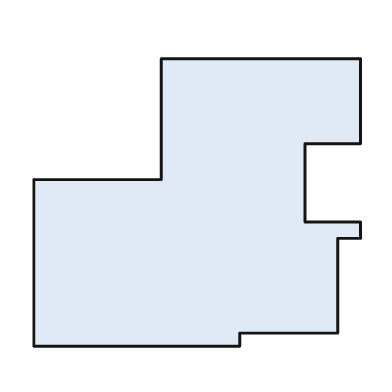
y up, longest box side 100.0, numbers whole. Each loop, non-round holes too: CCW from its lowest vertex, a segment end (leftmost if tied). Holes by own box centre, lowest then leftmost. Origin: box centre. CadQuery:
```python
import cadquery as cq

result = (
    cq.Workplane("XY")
    .moveTo(-50.0, -44.0)
    .lineTo(13.0, -44.0)
    .lineTo(13.0, -40.0)
    .lineTo(43.0, -40.0)
    .lineTo(43.0, -11.0)
    .lineTo(50.0, -11.0)
    .lineTo(50.0, -6.0)
    .lineTo(33.0, -6.0)
    .lineTo(33.0, 18.0)
    .lineTo(50.0, 18.0)
    .lineTo(50.0, 44.0)
    .lineTo(-11.0, 44.0)
    .lineTo(-11.0, 7.0)
    .lineTo(-50.0, 7.0)
    .close()
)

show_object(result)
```